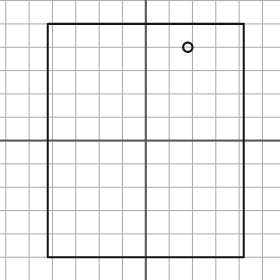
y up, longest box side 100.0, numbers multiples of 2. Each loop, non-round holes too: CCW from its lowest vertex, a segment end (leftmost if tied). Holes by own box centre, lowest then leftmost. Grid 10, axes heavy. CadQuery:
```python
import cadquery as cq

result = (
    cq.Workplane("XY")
    .moveTo(-42.0, -50.0)
    .lineTo(42.0, -50.0)
    .lineTo(42.0, 50.0)
    .lineTo(-42.0, 50.0)
    .close()
    .moveTo(18.0, 40.0)
    .circle(2.0)
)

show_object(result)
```